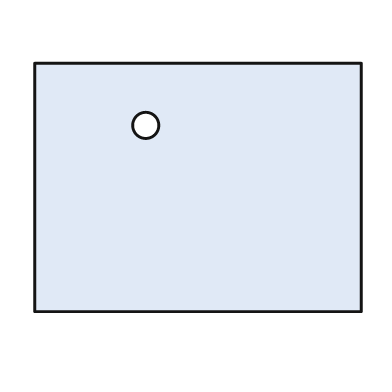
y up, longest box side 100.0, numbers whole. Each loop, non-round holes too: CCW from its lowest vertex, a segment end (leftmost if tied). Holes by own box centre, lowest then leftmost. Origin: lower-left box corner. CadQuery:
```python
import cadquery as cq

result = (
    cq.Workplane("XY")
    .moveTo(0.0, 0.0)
    .lineTo(100.0, 0.0)
    .lineTo(100.0, 76.0)
    .lineTo(0.0, 76.0)
    .close()
    .moveTo(34.0, 57.0)
    .circle(4.0)
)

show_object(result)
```